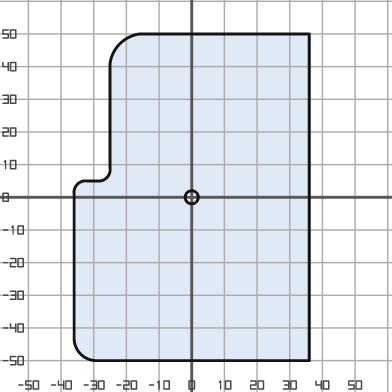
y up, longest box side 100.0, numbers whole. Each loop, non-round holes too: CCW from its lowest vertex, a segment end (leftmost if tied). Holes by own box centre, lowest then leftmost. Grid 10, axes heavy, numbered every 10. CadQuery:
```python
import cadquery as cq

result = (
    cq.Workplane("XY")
    .moveTo(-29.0, -50.0)
    .lineTo(36.0, -50.0)
    .lineTo(36.0, 50.0)
    .lineTo(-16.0, 50.0)
    .threePointArc((-22.0, 47.0), (-25.0, 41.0))
    .lineTo(-25.0, 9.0)
    .threePointArc((-26.0, 6.0), (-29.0, 5.0))
    .lineTo(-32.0, 5.0)
    .threePointArc((-35.0, 4.0), (-36.0, 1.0))
    .lineTo(-36.0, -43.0)
    .threePointArc((-34.0, -48.0), (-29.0, -50.0))
    .close()
    .moveTo(0.0, 0.0)
    .circle(2.0)
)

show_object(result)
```